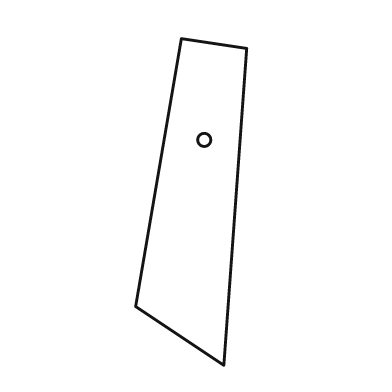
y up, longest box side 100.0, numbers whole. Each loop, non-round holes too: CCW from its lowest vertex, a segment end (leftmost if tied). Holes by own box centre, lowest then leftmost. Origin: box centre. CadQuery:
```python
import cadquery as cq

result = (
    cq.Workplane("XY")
    .moveTo(10.0, -50.0)
    .lineTo(17.0, 47.0)
    .lineTo(-3.0, 50.0)
    .lineTo(-17.0, -32.0)
    .close()
    .moveTo(4.0, 19.0)
    .circle(2.0)
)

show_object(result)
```